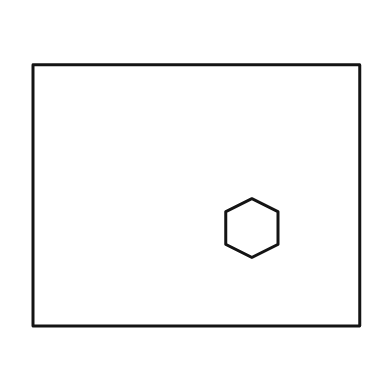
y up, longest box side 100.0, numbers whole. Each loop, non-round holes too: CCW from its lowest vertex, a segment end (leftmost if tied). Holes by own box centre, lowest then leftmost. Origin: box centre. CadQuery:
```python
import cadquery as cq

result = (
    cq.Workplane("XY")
    .moveTo(-50.0, -40.0)
    .lineTo(50.0, -40.0)
    .lineTo(50.0, 40.0)
    .lineTo(-50.0, 40.0)
    .close()
    .moveTo(17.0, -19.0)
    .lineTo(25.0, -15.0)
    .lineTo(25.0, -5.0)
    .lineTo(17.0, -1.0)
    .lineTo(9.0, -5.0)
    .lineTo(9.0, -15.0)
    .close()
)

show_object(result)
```